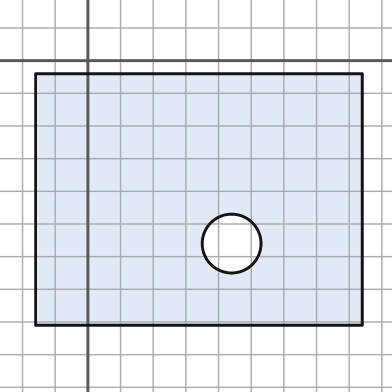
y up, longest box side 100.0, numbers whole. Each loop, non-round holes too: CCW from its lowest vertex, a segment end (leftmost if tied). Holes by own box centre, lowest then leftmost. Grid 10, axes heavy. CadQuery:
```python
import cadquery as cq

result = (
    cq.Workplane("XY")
    .moveTo(-16.0, -81.0)
    .lineTo(84.0, -81.0)
    .lineTo(84.0, -4.0)
    .lineTo(-16.0, -4.0)
    .close()
    .moveTo(44.0, -56.0)
    .circle(9.0)
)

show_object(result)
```